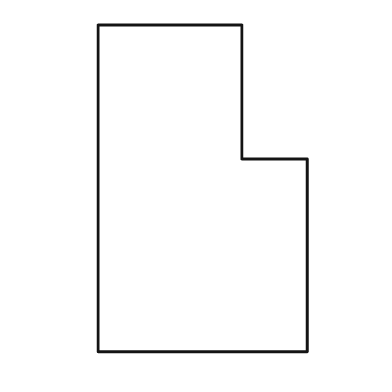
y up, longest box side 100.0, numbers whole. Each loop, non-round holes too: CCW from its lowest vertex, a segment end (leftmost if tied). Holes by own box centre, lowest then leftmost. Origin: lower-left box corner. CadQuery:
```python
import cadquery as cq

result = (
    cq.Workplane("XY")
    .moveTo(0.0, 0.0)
    .lineTo(64.0, 0.0)
    .lineTo(64.0, 59.0)
    .lineTo(44.0, 59.0)
    .lineTo(44.0, 100.0)
    .lineTo(0.0, 100.0)
    .close()
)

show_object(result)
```